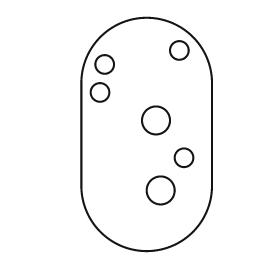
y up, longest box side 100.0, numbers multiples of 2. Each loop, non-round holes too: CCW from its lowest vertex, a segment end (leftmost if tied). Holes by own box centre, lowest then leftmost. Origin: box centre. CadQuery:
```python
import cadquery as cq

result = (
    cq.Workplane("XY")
    .moveTo(-28.0, -22.0)
    .threePointArc((0.0, -50.0), (28.0, -22.0))
    .lineTo(28.0, 22.0)
    .threePointArc((0.0, 50.0), (-28.0, 22.0))
    .close()
    .moveTo(6.0, -24.0)
    .circle(6.0)
    .moveTo(16.0, -10.0)
    .circle(4.0)
    .moveTo(4.0, 6.0)
    .circle(6.0)
    .moveTo(-20.0, 18.0)
    .circle(4.0)
    .moveTo(-18.0, 30.0)
    .circle(4.0)
    .moveTo(14.0, 36.0)
    .circle(4.0)
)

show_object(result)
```